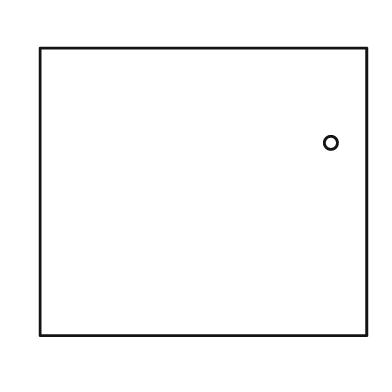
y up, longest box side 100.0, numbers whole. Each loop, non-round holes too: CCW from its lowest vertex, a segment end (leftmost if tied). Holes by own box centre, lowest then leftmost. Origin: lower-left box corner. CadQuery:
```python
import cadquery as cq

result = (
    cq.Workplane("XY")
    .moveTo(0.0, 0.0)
    .lineTo(100.0, 0.0)
    .lineTo(100.0, 88.0)
    .lineTo(0.0, 88.0)
    .close()
    .moveTo(89.0, 59.0)
    .circle(2.0)
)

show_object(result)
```